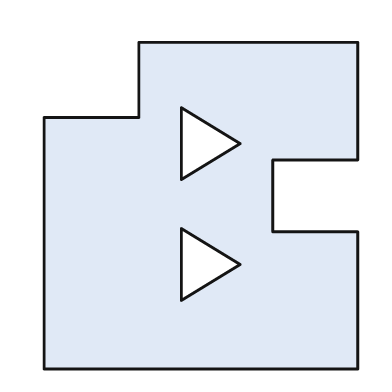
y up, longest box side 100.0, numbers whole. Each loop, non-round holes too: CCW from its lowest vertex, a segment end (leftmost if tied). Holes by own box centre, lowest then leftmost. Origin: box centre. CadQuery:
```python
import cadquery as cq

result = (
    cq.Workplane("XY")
    .moveTo(-48.0, -50.0)
    .lineTo(48.0, -50.0)
    .lineTo(48.0, -8.0)
    .lineTo(22.0, -8.0)
    .lineTo(22.0, 14.0)
    .lineTo(48.0, 14.0)
    .lineTo(48.0, 50.0)
    .lineTo(-19.0, 50.0)
    .lineTo(-19.0, 27.0)
    .lineTo(-48.0, 27.0)
    .close()
    .moveTo(-6.0, -29.0)
    .lineTo(12.0, -18.0)
    .lineTo(-6.0, -7.0)
    .close()
    .moveTo(-6.0, 8.0)
    .lineTo(12.0, 19.0)
    .lineTo(-6.0, 30.0)
    .close()
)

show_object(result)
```